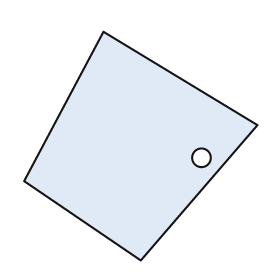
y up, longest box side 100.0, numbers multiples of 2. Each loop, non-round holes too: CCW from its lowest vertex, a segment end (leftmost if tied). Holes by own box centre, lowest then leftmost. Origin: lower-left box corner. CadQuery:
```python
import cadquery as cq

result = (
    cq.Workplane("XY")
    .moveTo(50.0, 0.0)
    .lineTo(100.0, 58.0)
    .lineTo(34.0, 98.0)
    .lineTo(0.0, 34.0)
    .close()
    .moveTo(76.0, 44.0)
    .circle(4.0)
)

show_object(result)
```